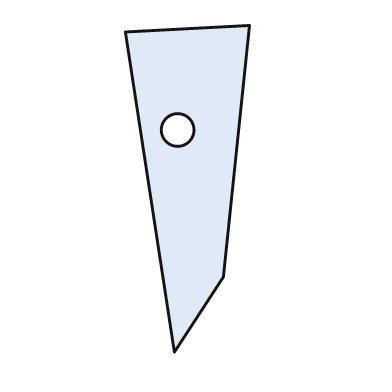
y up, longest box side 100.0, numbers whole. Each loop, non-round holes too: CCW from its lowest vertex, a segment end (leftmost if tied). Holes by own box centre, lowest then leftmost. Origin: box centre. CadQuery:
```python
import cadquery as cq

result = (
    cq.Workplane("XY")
    .moveTo(-4.0, -50.0)
    .lineTo(11.0, -27.0)
    .lineTo(19.0, 50.0)
    .lineTo(-19.0, 48.0)
    .close()
    .moveTo(-3.0, 18.0)
    .circle(5.0)
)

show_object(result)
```